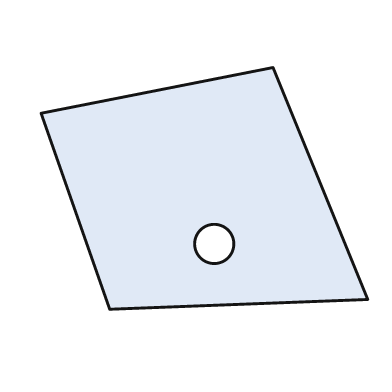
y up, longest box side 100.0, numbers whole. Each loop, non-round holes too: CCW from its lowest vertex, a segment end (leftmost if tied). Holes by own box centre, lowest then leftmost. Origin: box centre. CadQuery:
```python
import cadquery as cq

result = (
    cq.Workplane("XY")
    .moveTo(-29.0, -37.0)
    .lineTo(50.0, -34.0)
    .lineTo(21.0, 37.0)
    .lineTo(-50.0, 23.0)
    .close()
    .moveTo(3.0, -17.0)
    .circle(6.0)
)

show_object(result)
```